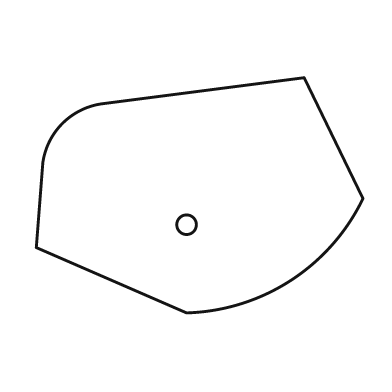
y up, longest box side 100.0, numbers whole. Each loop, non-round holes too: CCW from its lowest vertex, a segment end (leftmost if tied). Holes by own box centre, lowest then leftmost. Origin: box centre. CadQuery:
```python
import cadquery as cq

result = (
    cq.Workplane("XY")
    .moveTo(-4.0, -36.0)
    .threePointArc((28.0, -26.0), (50.0, -1.0))
    .lineTo(32.0, 36.0)
    .lineTo(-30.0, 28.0)
    .threePointArc((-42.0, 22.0), (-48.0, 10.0))
    .lineTo(-50.0, -16.0)
    .close()
    .moveTo(-4.0, -9.0)
    .circle(3.0)
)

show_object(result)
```